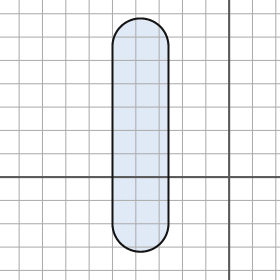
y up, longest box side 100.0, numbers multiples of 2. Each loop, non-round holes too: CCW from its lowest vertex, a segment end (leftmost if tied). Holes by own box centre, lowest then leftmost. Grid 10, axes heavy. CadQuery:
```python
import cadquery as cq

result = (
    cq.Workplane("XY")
    .moveTo(-50.0, -20.0)
    .threePointArc((-38.0, -32.0), (-26.0, -20.0))
    .lineTo(-26.0, 56.0)
    .threePointArc((-38.0, 68.0), (-50.0, 56.0))
    .close()
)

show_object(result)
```